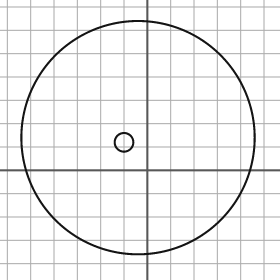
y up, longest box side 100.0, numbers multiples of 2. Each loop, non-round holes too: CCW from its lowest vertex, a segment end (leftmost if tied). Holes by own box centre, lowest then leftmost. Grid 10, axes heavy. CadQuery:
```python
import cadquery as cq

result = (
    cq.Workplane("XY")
    .moveTo(-4.0, 14.0)
    .circle(50.0)
    .moveTo(-10.0, 12.0)
    .circle(4.0)
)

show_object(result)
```